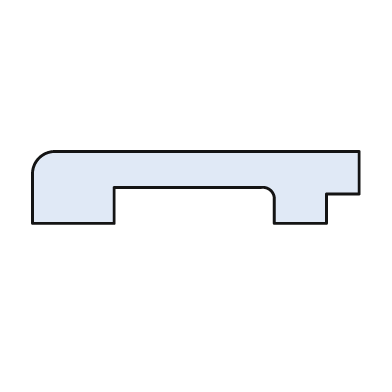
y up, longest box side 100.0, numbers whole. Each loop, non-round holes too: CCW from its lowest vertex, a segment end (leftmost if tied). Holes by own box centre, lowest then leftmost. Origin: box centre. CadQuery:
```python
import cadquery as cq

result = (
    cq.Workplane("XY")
    .moveTo(-50.0, -11.0)
    .lineTo(-25.0, -11.0)
    .lineTo(-25.0, 0.0)
    .lineTo(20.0, 0.0)
    .threePointArc((23.0, -1.0), (24.0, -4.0))
    .lineTo(24.0, -11.0)
    .lineTo(40.0, -11.0)
    .lineTo(40.0, -2.0)
    .lineTo(50.0, -2.0)
    .lineTo(50.0, 11.0)
    .lineTo(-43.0, 11.0)
    .threePointArc((-48.0, 9.0), (-50.0, 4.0))
    .close()
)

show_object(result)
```